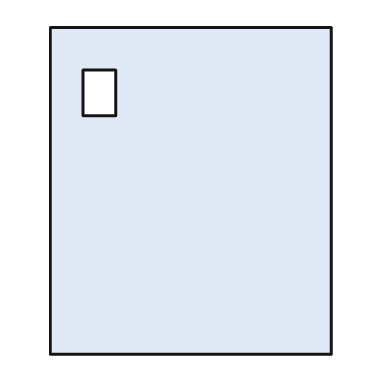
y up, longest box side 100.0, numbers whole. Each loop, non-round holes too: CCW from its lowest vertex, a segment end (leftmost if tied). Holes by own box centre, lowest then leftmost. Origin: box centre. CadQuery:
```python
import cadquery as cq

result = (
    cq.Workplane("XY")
    .moveTo(-43.0, -50.0)
    .lineTo(43.0, -50.0)
    .lineTo(43.0, 50.0)
    .lineTo(-43.0, 50.0)
    .close()
    .moveTo(-33.0, 23.0)
    .lineTo(-23.0, 23.0)
    .lineTo(-23.0, 37.0)
    .lineTo(-33.0, 37.0)
    .close()
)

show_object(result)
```